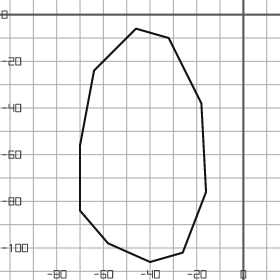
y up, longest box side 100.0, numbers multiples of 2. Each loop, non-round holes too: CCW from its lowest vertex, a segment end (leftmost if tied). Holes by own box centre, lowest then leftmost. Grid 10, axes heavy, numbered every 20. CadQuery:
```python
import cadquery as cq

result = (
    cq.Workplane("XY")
    .moveTo(-40.0, -106.0)
    .lineTo(-26.0, -102.0)
    .lineTo(-16.0, -76.0)
    .lineTo(-18.0, -38.0)
    .lineTo(-32.0, -10.0)
    .lineTo(-46.0, -6.0)
    .lineTo(-64.0, -24.0)
    .lineTo(-70.0, -56.0)
    .lineTo(-70.0, -84.0)
    .lineTo(-58.0, -98.0)
    .close()
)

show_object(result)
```